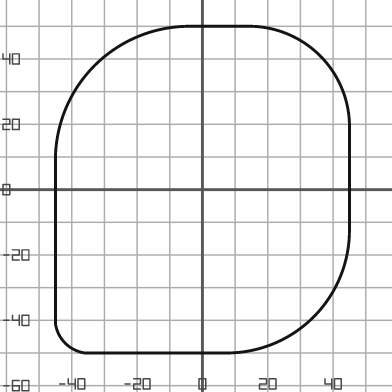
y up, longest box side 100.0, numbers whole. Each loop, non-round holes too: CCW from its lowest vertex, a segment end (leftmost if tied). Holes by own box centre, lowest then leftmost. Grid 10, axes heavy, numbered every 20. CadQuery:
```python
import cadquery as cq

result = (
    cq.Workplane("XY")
    .moveTo(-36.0, -50.0)
    .lineTo(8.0, -50.0)
    .threePointArc((34.0, -39.0), (45.0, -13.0))
    .lineTo(45.0, 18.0)
    .threePointArc((36.0, 41.0), (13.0, 50.0))
    .lineTo(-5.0, 50.0)
    .threePointArc((-33.0, 38.0), (-45.0, 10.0))
    .lineTo(-45.0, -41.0)
    .threePointArc((-42.0, -47.0), (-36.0, -50.0))
    .close()
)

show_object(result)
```